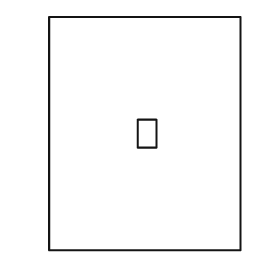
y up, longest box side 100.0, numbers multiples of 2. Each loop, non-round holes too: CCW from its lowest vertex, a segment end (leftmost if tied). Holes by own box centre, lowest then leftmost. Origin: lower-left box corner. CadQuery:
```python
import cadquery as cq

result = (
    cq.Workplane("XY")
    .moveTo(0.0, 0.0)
    .lineTo(82.0, 0.0)
    .lineTo(82.0, 100.0)
    .lineTo(0.0, 100.0)
    .close()
    .moveTo(38.0, 44.0)
    .lineTo(46.0, 44.0)
    .lineTo(46.0, 56.0)
    .lineTo(38.0, 56.0)
    .close()
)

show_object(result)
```